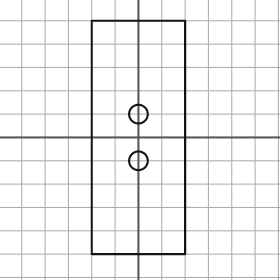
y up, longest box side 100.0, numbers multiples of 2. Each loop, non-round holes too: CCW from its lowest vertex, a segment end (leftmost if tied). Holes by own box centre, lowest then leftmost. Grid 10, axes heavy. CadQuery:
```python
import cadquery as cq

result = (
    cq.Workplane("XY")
    .moveTo(-20.0, -50.0)
    .lineTo(20.0, -50.0)
    .lineTo(20.0, 50.0)
    .lineTo(-20.0, 50.0)
    .close()
    .moveTo(0.0, -10.0)
    .circle(4.0)
    .moveTo(0.0, 10.0)
    .circle(4.0)
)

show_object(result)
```